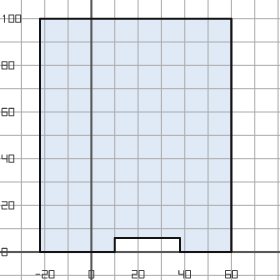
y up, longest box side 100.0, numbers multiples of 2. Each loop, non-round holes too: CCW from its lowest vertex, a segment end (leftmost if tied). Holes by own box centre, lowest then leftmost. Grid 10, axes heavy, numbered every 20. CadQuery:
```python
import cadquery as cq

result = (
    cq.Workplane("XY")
    .moveTo(-22.0, 0.0)
    .lineTo(10.0, 0.0)
    .lineTo(10.0, 6.0)
    .lineTo(38.0, 6.0)
    .lineTo(38.0, 0.0)
    .lineTo(60.0, 0.0)
    .lineTo(60.0, 100.0)
    .lineTo(-22.0, 100.0)
    .close()
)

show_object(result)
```